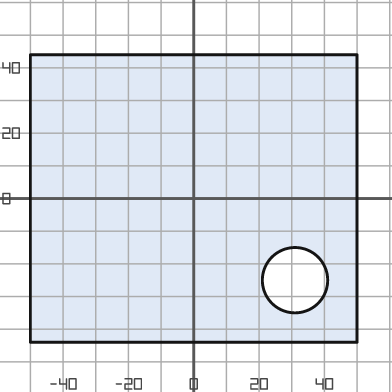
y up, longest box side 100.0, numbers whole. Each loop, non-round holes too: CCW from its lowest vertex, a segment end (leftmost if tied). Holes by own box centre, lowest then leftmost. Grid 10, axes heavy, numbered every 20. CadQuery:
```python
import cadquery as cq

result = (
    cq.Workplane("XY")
    .moveTo(-50.0, -44.0)
    .lineTo(50.0, -44.0)
    .lineTo(50.0, 44.0)
    .lineTo(-50.0, 44.0)
    .close()
    .moveTo(31.0, -25.0)
    .circle(10.0)
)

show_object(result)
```